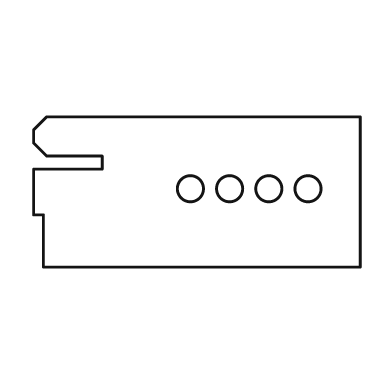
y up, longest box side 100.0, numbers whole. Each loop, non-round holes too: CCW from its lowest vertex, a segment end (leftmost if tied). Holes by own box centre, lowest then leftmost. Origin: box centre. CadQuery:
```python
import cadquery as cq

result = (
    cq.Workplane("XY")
    .moveTo(-47.0, -23.0)
    .lineTo(50.0, -23.0)
    .lineTo(50.0, 23.0)
    .lineTo(-46.0, 23.0)
    .lineTo(-50.0, 19.0)
    .lineTo(-50.0, 15.0)
    .lineTo(-46.0, 11.0)
    .lineTo(-29.0, 11.0)
    .lineTo(-29.0, 7.0)
    .lineTo(-50.0, 7.0)
    .lineTo(-50.0, -7.0)
    .lineTo(-47.0, -7.0)
    .close()
    .moveTo(-2.0, 1.0)
    .circle(4.0)
    .moveTo(10.0, 1.0)
    .circle(4.0)
    .moveTo(22.0, 1.0)
    .circle(4.0)
    .moveTo(34.0, 1.0)
    .circle(4.0)
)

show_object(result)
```